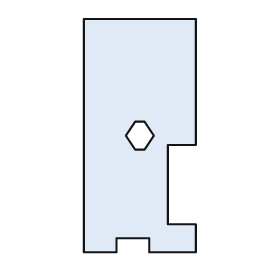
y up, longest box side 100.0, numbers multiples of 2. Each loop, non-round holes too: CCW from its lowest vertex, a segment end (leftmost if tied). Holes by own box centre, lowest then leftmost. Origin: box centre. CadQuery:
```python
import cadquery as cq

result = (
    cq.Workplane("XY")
    .moveTo(-24.0, -50.0)
    .lineTo(-10.0, -50.0)
    .lineTo(-10.0, -44.0)
    .lineTo(4.0, -44.0)
    .lineTo(4.0, -50.0)
    .lineTo(24.0, -50.0)
    .lineTo(24.0, -38.0)
    .lineTo(12.0, -38.0)
    .lineTo(12.0, -4.0)
    .lineTo(24.0, -4.0)
    .lineTo(24.0, 50.0)
    .lineTo(-24.0, 50.0)
    .close()
    .moveTo(-2.0, -6.0)
    .lineTo(2.0, -6.0)
    .lineTo(6.0, 0.0)
    .lineTo(2.0, 6.0)
    .lineTo(-2.0, 6.0)
    .lineTo(-6.0, 0.0)
    .close()
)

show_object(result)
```